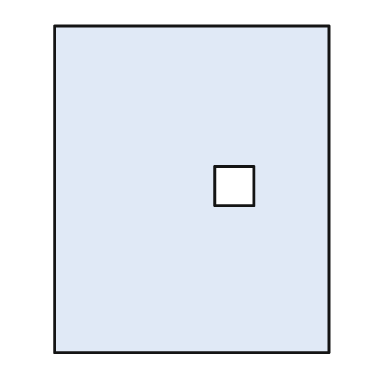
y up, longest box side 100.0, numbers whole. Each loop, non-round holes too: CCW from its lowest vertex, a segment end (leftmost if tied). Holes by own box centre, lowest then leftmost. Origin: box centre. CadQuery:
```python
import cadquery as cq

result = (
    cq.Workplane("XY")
    .moveTo(-42.0, -50.0)
    .lineTo(42.0, -50.0)
    .lineTo(42.0, 50.0)
    .lineTo(-42.0, 50.0)
    .close()
    .moveTo(7.0, -5.0)
    .lineTo(19.0, -5.0)
    .lineTo(19.0, 7.0)
    .lineTo(7.0, 7.0)
    .close()
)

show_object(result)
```